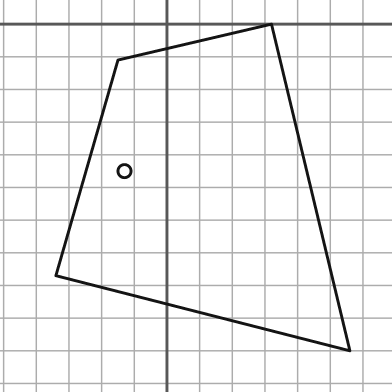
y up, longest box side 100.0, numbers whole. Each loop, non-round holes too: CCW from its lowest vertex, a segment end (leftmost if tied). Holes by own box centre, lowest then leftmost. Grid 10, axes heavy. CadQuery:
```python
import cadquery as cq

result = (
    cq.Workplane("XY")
    .moveTo(56.0, -100.0)
    .lineTo(32.0, 0.0)
    .lineTo(-15.0, -11.0)
    .lineTo(-34.0, -77.0)
    .close()
    .moveTo(-13.0, -45.0)
    .circle(2.0)
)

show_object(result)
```